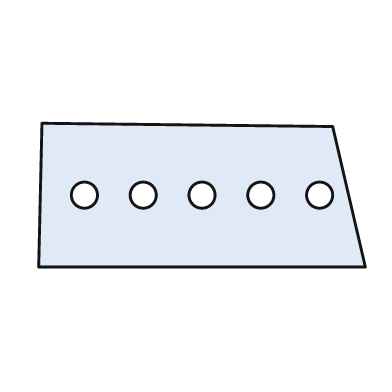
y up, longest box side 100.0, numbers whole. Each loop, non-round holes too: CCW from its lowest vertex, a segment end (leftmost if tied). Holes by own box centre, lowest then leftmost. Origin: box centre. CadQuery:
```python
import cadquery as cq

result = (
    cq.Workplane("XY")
    .moveTo(-50.0, -22.0)
    .lineTo(50.0, -22.0)
    .lineTo(40.0, 21.0)
    .lineTo(-49.0, 22.0)
    .close()
    .moveTo(-36.0, 0.0)
    .circle(4.0)
    .moveTo(-18.0, 0.0)
    .circle(4.0)
    .moveTo(0.0, 0.0)
    .circle(4.0)
    .moveTo(18.0, 0.0)
    .circle(4.0)
    .moveTo(36.0, 0.0)
    .circle(4.0)
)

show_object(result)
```